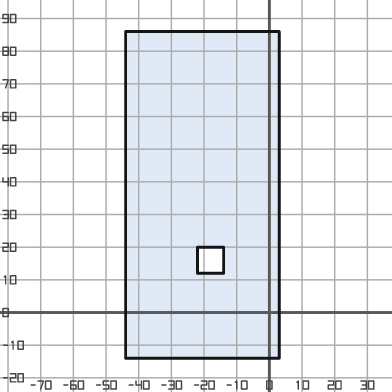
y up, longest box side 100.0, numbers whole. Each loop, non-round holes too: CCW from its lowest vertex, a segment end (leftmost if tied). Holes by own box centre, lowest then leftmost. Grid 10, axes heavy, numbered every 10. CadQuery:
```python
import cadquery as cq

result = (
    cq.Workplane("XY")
    .moveTo(-44.0, -14.0)
    .lineTo(3.0, -14.0)
    .lineTo(3.0, 86.0)
    .lineTo(-44.0, 86.0)
    .close()
    .moveTo(-22.0, 12.0)
    .lineTo(-14.0, 12.0)
    .lineTo(-14.0, 20.0)
    .lineTo(-22.0, 20.0)
    .close()
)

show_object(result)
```